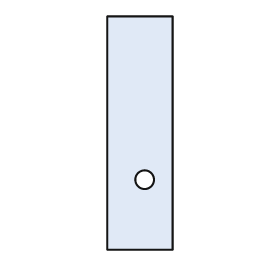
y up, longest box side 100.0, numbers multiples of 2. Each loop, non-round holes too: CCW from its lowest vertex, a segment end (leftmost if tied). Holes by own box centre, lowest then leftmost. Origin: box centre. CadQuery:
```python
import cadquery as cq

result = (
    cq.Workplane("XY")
    .moveTo(-14.0, -50.0)
    .lineTo(14.0, -50.0)
    .lineTo(14.0, 50.0)
    .lineTo(-14.0, 50.0)
    .close()
    .moveTo(2.0, -20.0)
    .circle(4.0)
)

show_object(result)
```